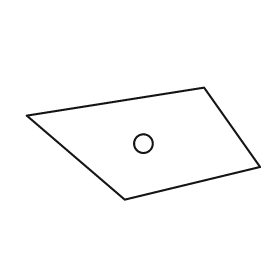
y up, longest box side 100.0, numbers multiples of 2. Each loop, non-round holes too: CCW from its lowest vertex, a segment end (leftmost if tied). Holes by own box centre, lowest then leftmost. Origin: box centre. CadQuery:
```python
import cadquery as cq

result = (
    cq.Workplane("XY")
    .moveTo(-8.0, -24.0)
    .lineTo(50.0, -10.0)
    .lineTo(26.0, 24.0)
    .lineTo(-50.0, 12.0)
    .close()
    .moveTo(0.0, 0.0)
    .circle(4.0)
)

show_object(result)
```